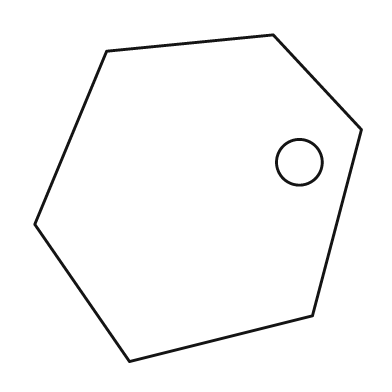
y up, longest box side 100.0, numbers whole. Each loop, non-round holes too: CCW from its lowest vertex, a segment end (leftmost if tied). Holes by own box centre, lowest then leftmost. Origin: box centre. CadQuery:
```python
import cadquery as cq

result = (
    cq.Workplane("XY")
    .moveTo(-21.0, -50.0)
    .lineTo(35.0, -36.0)
    .lineTo(50.0, 21.0)
    .lineTo(23.0, 50.0)
    .lineTo(-28.0, 45.0)
    .lineTo(-50.0, -8.0)
    .close()
    .moveTo(31.0, 11.0)
    .circle(7.0)
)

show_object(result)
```